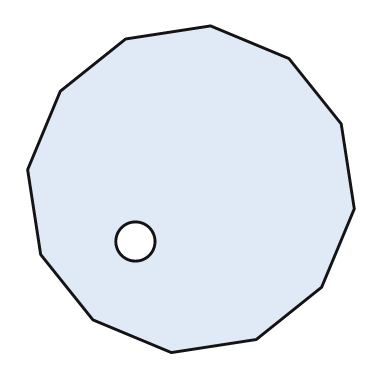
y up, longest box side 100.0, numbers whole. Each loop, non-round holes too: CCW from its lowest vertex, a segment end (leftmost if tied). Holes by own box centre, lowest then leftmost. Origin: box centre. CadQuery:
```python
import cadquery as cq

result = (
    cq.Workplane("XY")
    .moveTo(-6.0, -50.0)
    .lineTo(20.0, -46.0)
    .lineTo(40.0, -30.0)
    .lineTo(50.0, -6.0)
    .lineTo(46.0, 20.0)
    .lineTo(30.0, 40.0)
    .lineTo(6.0, 50.0)
    .lineTo(-20.0, 46.0)
    .lineTo(-40.0, 30.0)
    .lineTo(-50.0, 6.0)
    .lineTo(-46.0, -20.0)
    .lineTo(-30.0, -40.0)
    .close()
    .moveTo(-17.0, -16.0)
    .circle(6.0)
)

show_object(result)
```